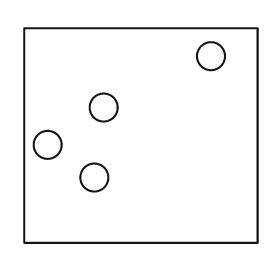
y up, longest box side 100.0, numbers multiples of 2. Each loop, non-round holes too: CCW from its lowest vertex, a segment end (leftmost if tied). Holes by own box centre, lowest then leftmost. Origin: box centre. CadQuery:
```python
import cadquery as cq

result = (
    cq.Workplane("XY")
    .moveTo(-50.0, -46.0)
    .lineTo(50.0, -46.0)
    .lineTo(50.0, 46.0)
    .lineTo(-50.0, 46.0)
    .close()
    .moveTo(-20.0, -18.0)
    .circle(6.0)
    .moveTo(-40.0, -4.0)
    .circle(6.0)
    .moveTo(-16.0, 12.0)
    .circle(6.0)
    .moveTo(30.0, 34.0)
    .circle(6.0)
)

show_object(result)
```